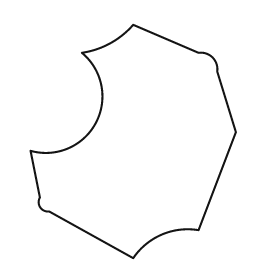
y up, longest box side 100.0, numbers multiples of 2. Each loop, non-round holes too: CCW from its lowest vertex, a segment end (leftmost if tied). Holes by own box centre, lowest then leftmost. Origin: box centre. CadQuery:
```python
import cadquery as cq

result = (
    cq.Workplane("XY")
    .moveTo(0.0, -50.0)
    .threePointArc((12.0, -40.0), (28.0, -38.0))
    .lineTo(44.0, 4.0)
    .lineTo(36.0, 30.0)
    .threePointArc((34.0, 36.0), (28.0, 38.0))
    .lineTo(0.0, 50.0)
    .threePointArc((-10.0, 42.0), (-22.0, 38.0))
    .threePointArc((-16.0, 8.0), (-44.0, -4.0))
    .lineTo(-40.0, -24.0)
    .threePointArc((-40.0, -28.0), (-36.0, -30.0))
    .close()
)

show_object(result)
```